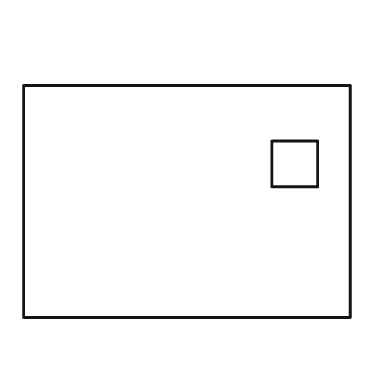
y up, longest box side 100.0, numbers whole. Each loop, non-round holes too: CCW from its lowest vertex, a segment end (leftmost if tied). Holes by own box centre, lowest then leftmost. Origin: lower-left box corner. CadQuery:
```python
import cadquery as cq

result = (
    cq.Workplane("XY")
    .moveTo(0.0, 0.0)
    .lineTo(100.0, 0.0)
    .lineTo(100.0, 71.0)
    .lineTo(0.0, 71.0)
    .close()
    .moveTo(76.0, 40.0)
    .lineTo(90.0, 40.0)
    .lineTo(90.0, 54.0)
    .lineTo(76.0, 54.0)
    .close()
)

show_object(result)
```